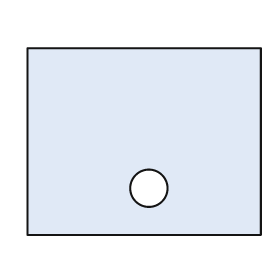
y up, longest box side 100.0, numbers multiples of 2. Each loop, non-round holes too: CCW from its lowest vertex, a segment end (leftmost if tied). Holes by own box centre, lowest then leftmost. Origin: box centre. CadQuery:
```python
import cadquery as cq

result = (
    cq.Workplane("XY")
    .moveTo(-50.0, -40.0)
    .lineTo(50.0, -40.0)
    .lineTo(50.0, 40.0)
    .lineTo(-50.0, 40.0)
    .close()
    .moveTo(2.0, -20.0)
    .circle(8.0)
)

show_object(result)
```